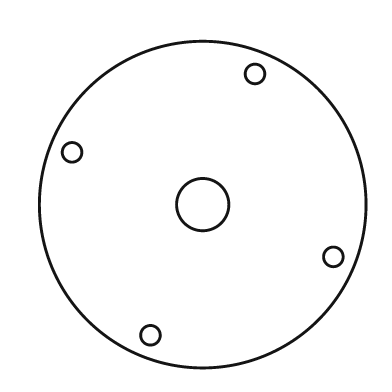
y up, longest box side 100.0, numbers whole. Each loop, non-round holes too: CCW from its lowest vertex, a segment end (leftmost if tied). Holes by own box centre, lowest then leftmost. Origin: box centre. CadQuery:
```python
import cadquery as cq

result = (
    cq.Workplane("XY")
    .moveTo(0.0, 0.0)
    .circle(50.0)
    .moveTo(-16.0, -40.0)
    .circle(3.0)
    .moveTo(40.0, -16.0)
    .circle(3.0)
    .moveTo(0.0, 0.0)
    .circle(8.0)
    .moveTo(-40.0, 16.0)
    .circle(3.0)
    .moveTo(16.0, 40.0)
    .circle(3.0)
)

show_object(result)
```